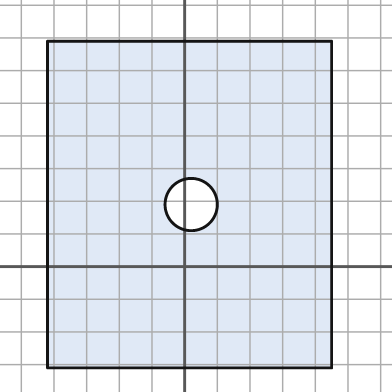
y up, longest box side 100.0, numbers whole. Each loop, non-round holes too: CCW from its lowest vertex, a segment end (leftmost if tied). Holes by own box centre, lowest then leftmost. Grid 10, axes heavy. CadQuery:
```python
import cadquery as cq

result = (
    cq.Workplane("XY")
    .moveTo(-42.0, -31.0)
    .lineTo(45.0, -31.0)
    .lineTo(45.0, 69.0)
    .lineTo(-42.0, 69.0)
    .close()
    .moveTo(2.0, 19.0)
    .circle(8.0)
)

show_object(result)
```